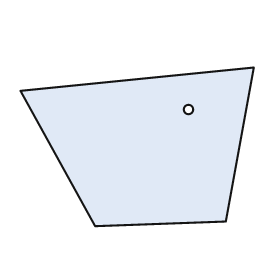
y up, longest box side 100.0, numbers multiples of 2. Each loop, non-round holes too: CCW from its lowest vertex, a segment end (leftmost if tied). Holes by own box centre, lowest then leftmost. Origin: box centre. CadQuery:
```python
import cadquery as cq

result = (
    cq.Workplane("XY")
    .moveTo(-18.0, -34.0)
    .lineTo(38.0, -32.0)
    .lineTo(50.0, 34.0)
    .lineTo(-50.0, 24.0)
    .close()
    .moveTo(22.0, 16.0)
    .circle(2.0)
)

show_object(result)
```